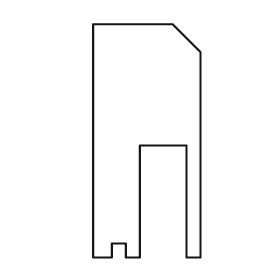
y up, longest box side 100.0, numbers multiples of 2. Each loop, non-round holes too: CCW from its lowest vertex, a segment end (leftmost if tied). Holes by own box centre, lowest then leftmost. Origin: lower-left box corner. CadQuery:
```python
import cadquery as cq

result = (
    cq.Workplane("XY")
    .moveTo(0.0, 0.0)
    .lineTo(8.0, 0.0)
    .lineTo(8.0, 6.0)
    .lineTo(14.0, 6.0)
    .lineTo(14.0, 0.0)
    .lineTo(20.0, 0.0)
    .lineTo(20.0, 48.0)
    .lineTo(40.0, 48.0)
    .lineTo(40.0, 0.0)
    .lineTo(46.0, 0.0)
    .lineTo(46.0, 88.0)
    .lineTo(34.0, 100.0)
    .lineTo(0.0, 100.0)
    .close()
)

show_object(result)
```